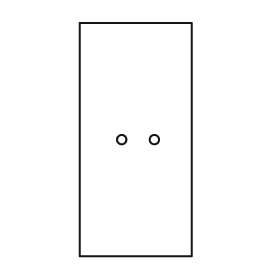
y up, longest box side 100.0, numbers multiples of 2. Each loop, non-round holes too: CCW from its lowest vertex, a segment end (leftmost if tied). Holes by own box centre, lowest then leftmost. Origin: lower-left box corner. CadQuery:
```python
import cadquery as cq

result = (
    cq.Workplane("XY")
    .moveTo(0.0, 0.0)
    .lineTo(48.0, 0.0)
    .lineTo(48.0, 100.0)
    .lineTo(0.0, 100.0)
    .close()
    .moveTo(18.0, 50.0)
    .circle(2.0)
    .moveTo(32.0, 50.0)
    .circle(2.0)
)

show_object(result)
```